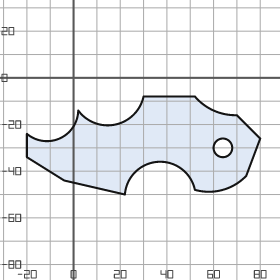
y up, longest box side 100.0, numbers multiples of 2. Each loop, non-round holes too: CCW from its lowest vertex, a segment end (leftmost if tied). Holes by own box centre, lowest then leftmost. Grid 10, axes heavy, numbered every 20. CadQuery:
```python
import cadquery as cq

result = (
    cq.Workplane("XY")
    .moveTo(22.0, -50.0)
    .threePointArc((36.0, -36.0), (52.0, -48.0))
    .threePointArc((64.0, -48.0), (74.0, -42.0))
    .lineTo(80.0, -26.0)
    .lineTo(70.0, -16.0)
    .threePointArc((60.0, -14.0), (52.0, -8.0))
    .lineTo(30.0, -8.0)
    .threePointArc((18.0, -20.0), (2.0, -14.0))
    .threePointArc((-6.0, -26.0), (-20.0, -24.0))
    .lineTo(-20.0, -34.0)
    .lineTo(-4.0, -44.0)
    .close()
    .moveTo(64.0, -30.0)
    .circle(4.0)
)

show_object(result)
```